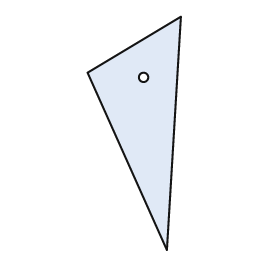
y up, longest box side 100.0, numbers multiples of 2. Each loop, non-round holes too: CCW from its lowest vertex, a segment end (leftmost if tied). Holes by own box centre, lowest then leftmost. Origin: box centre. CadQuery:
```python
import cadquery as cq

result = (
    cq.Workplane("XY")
    .moveTo(14.0, -50.0)
    .lineTo(20.0, 50.0)
    .lineTo(-20.0, 26.0)
    .close()
    .moveTo(4.0, 24.0)
    .circle(2.0)
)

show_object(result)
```